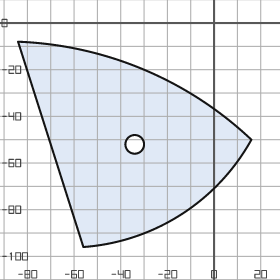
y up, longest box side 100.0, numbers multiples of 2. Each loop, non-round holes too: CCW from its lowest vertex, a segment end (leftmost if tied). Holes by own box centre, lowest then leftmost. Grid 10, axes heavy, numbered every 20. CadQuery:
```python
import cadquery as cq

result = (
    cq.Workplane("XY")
    .moveTo(-56.0, -96.0)
    .threePointArc((-14.0, -82.0), (16.0, -50.0))
    .threePointArc((-30.0, -20.0), (-84.0, -8.0))
    .close()
    .moveTo(-34.0, -52.0)
    .circle(4.0)
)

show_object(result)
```